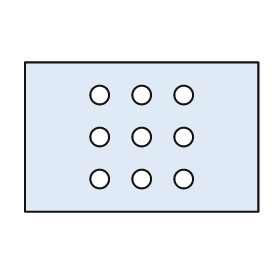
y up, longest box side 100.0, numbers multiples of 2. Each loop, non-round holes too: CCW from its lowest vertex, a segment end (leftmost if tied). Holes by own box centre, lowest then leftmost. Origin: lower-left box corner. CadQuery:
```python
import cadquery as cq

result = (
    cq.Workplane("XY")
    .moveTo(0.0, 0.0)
    .lineTo(100.0, 0.0)
    .lineTo(100.0, 64.0)
    .lineTo(0.0, 64.0)
    .close()
    .moveTo(32.0, 14.0)
    .circle(4.0)
    .moveTo(50.0, 14.0)
    .circle(4.0)
    .moveTo(68.0, 14.0)
    .circle(4.0)
    .moveTo(32.0, 32.0)
    .circle(4.0)
    .moveTo(50.0, 32.0)
    .circle(4.0)
    .moveTo(68.0, 32.0)
    .circle(4.0)
    .moveTo(32.0, 50.0)
    .circle(4.0)
    .moveTo(50.0, 50.0)
    .circle(4.0)
    .moveTo(68.0, 50.0)
    .circle(4.0)
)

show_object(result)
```